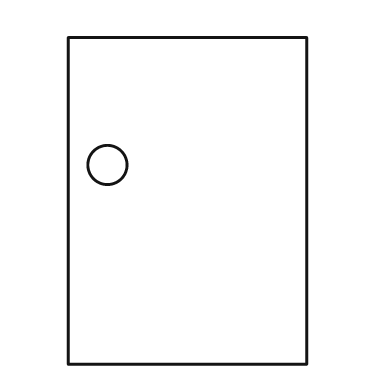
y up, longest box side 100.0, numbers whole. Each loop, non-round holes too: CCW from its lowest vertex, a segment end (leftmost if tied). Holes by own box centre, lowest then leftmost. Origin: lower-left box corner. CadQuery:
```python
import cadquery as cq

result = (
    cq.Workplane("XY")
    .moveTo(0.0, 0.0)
    .lineTo(73.0, 0.0)
    .lineTo(73.0, 100.0)
    .lineTo(0.0, 100.0)
    .close()
    .moveTo(12.0, 61.0)
    .circle(6.0)
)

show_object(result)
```